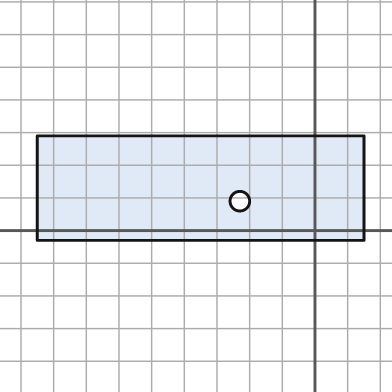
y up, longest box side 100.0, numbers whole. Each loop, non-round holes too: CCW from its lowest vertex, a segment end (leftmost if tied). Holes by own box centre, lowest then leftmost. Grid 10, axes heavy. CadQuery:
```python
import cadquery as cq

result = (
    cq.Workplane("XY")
    .moveTo(-85.0, -3.0)
    .lineTo(15.0, -3.0)
    .lineTo(15.0, 29.0)
    .lineTo(-85.0, 29.0)
    .close()
    .moveTo(-23.0, 9.0)
    .circle(3.0)
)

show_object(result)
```